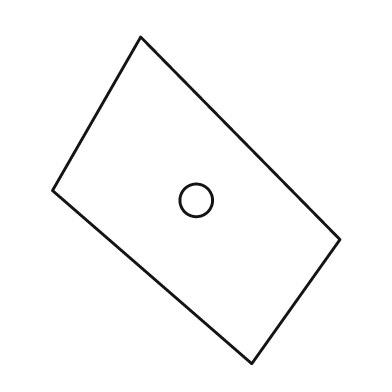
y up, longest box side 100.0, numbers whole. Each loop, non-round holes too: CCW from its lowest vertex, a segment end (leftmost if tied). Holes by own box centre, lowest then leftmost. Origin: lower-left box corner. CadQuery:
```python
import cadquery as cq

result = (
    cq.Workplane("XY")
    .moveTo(61.0, 0.0)
    .lineTo(88.0, 38.0)
    .lineTo(27.0, 100.0)
    .lineTo(0.0, 53.0)
    .close()
    .moveTo(44.0, 50.0)
    .circle(5.0)
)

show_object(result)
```